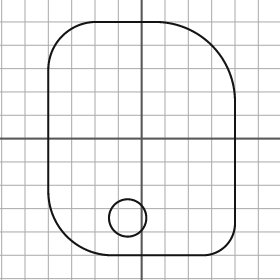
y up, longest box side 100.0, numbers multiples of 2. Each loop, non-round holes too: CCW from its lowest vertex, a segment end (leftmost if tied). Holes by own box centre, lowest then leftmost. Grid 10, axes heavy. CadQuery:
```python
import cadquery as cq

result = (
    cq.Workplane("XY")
    .moveTo(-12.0, -50.0)
    .lineTo(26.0, -50.0)
    .threePointArc((36.0, -46.0), (40.0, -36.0))
    .lineTo(40.0, 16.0)
    .threePointArc((30.0, 40.0), (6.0, 50.0))
    .lineTo(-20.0, 50.0)
    .threePointArc((-34.0, 44.0), (-40.0, 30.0))
    .lineTo(-40.0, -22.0)
    .threePointArc((-32.0, -42.0), (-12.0, -50.0))
    .close()
    .moveTo(-6.0, -34.0)
    .circle(8.0)
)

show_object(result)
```